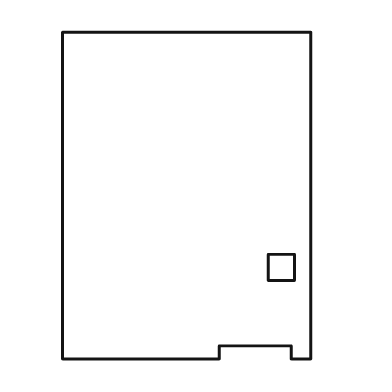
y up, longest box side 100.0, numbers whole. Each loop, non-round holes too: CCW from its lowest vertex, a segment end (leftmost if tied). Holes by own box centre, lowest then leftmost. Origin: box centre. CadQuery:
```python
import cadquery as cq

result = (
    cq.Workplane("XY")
    .moveTo(-38.0, -50.0)
    .lineTo(10.0, -50.0)
    .lineTo(10.0, -46.0)
    .lineTo(32.0, -46.0)
    .lineTo(32.0, -50.0)
    .lineTo(38.0, -50.0)
    .lineTo(38.0, 50.0)
    .lineTo(-38.0, 50.0)
    .close()
    .moveTo(25.0, -26.0)
    .lineTo(33.0, -26.0)
    .lineTo(33.0, -18.0)
    .lineTo(25.0, -18.0)
    .close()
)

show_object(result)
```